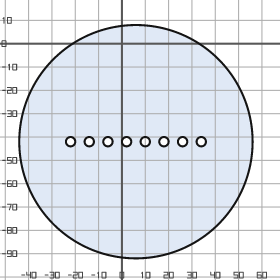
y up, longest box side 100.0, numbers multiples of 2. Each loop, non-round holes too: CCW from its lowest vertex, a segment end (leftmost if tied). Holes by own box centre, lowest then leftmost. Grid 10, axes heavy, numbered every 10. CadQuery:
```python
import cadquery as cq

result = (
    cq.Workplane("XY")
    .moveTo(6.0, -42.0)
    .circle(50.0)
    .moveTo(-22.0, -42.0)
    .circle(2.0)
    .moveTo(-14.0, -42.0)
    .circle(2.0)
    .moveTo(-6.0, -42.0)
    .circle(2.0)
    .moveTo(2.0, -42.0)
    .circle(2.0)
    .moveTo(10.0, -42.0)
    .circle(2.0)
    .moveTo(18.0, -42.0)
    .circle(2.0)
    .moveTo(26.0, -42.0)
    .circle(2.0)
    .moveTo(34.0, -42.0)
    .circle(2.0)
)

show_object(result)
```